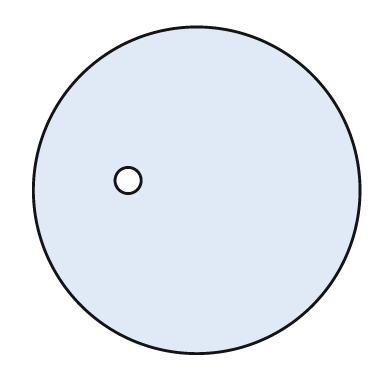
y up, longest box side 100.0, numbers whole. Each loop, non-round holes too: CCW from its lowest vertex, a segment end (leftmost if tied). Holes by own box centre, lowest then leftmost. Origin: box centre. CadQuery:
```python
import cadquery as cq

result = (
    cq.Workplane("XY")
    .moveTo(0.0, 0.0)
    .circle(50.0)
    .moveTo(-21.0, 3.0)
    .circle(4.0)
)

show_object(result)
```